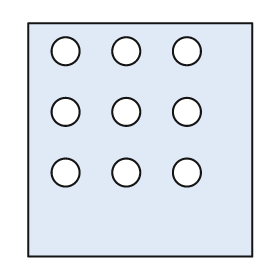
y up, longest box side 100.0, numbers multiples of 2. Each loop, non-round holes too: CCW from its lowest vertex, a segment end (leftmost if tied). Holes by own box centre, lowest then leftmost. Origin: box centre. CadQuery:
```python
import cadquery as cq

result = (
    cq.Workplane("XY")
    .moveTo(-48.0, -50.0)
    .lineTo(48.0, -50.0)
    .lineTo(48.0, 50.0)
    .lineTo(-48.0, 50.0)
    .close()
    .moveTo(-32.0, -14.0)
    .circle(6.0)
    .moveTo(-6.0, -14.0)
    .circle(6.0)
    .moveTo(20.0, -14.0)
    .circle(6.0)
    .moveTo(-32.0, 12.0)
    .circle(6.0)
    .moveTo(-6.0, 12.0)
    .circle(6.0)
    .moveTo(20.0, 12.0)
    .circle(6.0)
    .moveTo(-32.0, 38.0)
    .circle(6.0)
    .moveTo(-6.0, 38.0)
    .circle(6.0)
    .moveTo(20.0, 38.0)
    .circle(6.0)
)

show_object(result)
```